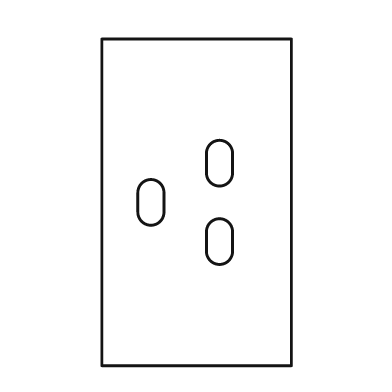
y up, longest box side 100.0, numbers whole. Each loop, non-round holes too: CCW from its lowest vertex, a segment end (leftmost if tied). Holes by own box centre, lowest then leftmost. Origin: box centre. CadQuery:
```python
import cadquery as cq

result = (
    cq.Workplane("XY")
    .moveTo(-29.0, -50.0)
    .lineTo(29.0, -50.0)
    .lineTo(29.0, 50.0)
    .lineTo(-29.0, 50.0)
    .close()
    .moveTo(3.0, -15.0)
    .threePointArc((7.0, -19.0), (11.0, -15.0))
    .lineTo(11.0, -9.0)
    .threePointArc((7.0, -5.0), (3.0, -9.0))
    .close()
    .moveTo(-18.0, -3.0)
    .threePointArc((-14.0, -7.0), (-10.0, -3.0))
    .lineTo(-10.0, 3.0)
    .threePointArc((-14.0, 7.0), (-18.0, 3.0))
    .close()
    .moveTo(3.0, 9.0)
    .threePointArc((7.0, 5.0), (11.0, 9.0))
    .lineTo(11.0, 15.0)
    .threePointArc((7.0, 19.0), (3.0, 15.0))
    .close()
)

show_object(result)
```